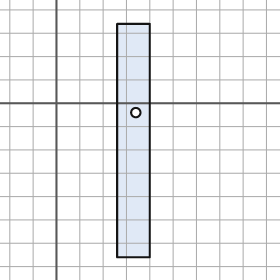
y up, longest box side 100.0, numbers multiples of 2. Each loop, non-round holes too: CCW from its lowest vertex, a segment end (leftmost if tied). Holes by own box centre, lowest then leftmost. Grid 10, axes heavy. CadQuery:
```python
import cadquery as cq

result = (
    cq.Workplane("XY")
    .moveTo(26.0, -66.0)
    .lineTo(40.0, -66.0)
    .lineTo(40.0, 34.0)
    .lineTo(26.0, 34.0)
    .close()
    .moveTo(34.0, -4.0)
    .circle(2.0)
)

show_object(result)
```